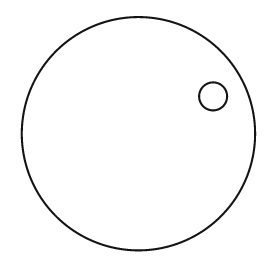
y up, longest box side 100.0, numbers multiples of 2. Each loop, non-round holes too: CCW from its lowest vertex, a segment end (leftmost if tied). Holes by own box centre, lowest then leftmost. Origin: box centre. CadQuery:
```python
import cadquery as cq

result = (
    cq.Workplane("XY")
    .moveTo(0.0, 0.0)
    .circle(50.0)
    .moveTo(32.0, 16.0)
    .circle(6.0)
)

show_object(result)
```